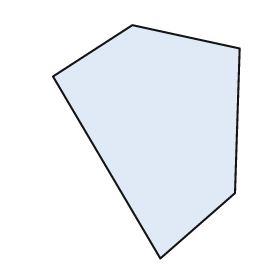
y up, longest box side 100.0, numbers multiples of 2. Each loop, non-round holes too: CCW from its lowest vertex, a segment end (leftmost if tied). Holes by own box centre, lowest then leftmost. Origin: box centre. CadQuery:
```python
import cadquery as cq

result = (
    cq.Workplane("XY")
    .moveTo(6.0, -50.0)
    .lineTo(38.0, -22.0)
    .lineTo(40.0, 40.0)
    .lineTo(-6.0, 50.0)
    .lineTo(-40.0, 28.0)
    .close()
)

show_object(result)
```